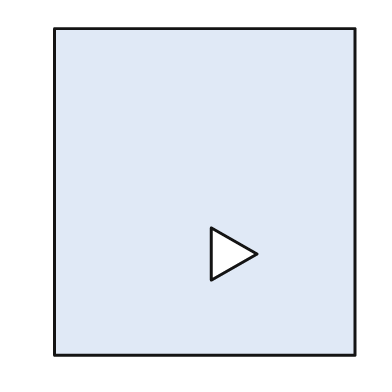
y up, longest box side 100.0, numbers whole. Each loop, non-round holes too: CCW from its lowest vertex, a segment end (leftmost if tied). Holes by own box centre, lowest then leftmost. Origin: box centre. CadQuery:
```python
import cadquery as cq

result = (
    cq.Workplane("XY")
    .moveTo(-46.0, -50.0)
    .lineTo(46.0, -50.0)
    .lineTo(46.0, 50.0)
    .lineTo(-46.0, 50.0)
    .close()
    .moveTo(2.0, -27.0)
    .lineTo(16.0, -19.0)
    .lineTo(2.0, -11.0)
    .close()
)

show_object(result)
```